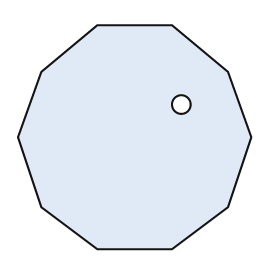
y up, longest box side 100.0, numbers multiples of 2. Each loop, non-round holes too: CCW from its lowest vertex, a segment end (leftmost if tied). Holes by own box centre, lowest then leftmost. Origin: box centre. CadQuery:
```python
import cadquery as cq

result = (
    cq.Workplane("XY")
    .moveTo(-16.0, -48.0)
    .lineTo(16.0, -48.0)
    .lineTo(40.0, -30.0)
    .lineTo(50.0, 0.0)
    .lineTo(40.0, 28.0)
    .lineTo(16.0, 48.0)
    .lineTo(-16.0, 48.0)
    .lineTo(-40.0, 28.0)
    .lineTo(-50.0, 0.0)
    .lineTo(-40.0, -30.0)
    .close()
    .moveTo(20.0, 14.0)
    .circle(4.0)
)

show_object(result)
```